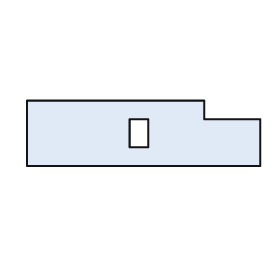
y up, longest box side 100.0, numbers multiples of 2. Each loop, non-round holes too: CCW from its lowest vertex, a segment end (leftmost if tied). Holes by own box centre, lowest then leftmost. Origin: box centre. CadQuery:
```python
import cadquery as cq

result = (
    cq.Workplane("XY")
    .moveTo(-50.0, -14.0)
    .lineTo(50.0, -14.0)
    .lineTo(50.0, 6.0)
    .lineTo(26.0, 6.0)
    .lineTo(26.0, 14.0)
    .lineTo(-50.0, 14.0)
    .close()
    .moveTo(-6.0, -6.0)
    .lineTo(2.0, -6.0)
    .lineTo(2.0, 6.0)
    .lineTo(-6.0, 6.0)
    .close()
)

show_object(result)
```